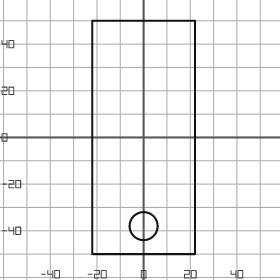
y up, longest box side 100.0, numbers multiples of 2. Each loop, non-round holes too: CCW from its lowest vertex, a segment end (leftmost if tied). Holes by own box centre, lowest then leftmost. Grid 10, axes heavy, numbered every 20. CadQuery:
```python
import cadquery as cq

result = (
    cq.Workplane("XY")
    .moveTo(-22.0, -50.0)
    .lineTo(22.0, -50.0)
    .lineTo(22.0, 50.0)
    .lineTo(-22.0, 50.0)
    .close()
    .moveTo(0.0, -38.0)
    .circle(6.0)
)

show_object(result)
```